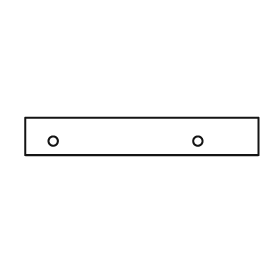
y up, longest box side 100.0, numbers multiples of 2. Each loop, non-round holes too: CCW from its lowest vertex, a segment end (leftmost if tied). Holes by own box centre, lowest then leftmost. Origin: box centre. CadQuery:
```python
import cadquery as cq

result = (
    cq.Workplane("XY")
    .moveTo(-50.0, -8.0)
    .lineTo(50.0, -8.0)
    .lineTo(50.0, 8.0)
    .lineTo(-50.0, 8.0)
    .close()
    .moveTo(-38.0, -2.0)
    .circle(2.0)
    .moveTo(24.0, -2.0)
    .circle(2.0)
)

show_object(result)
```